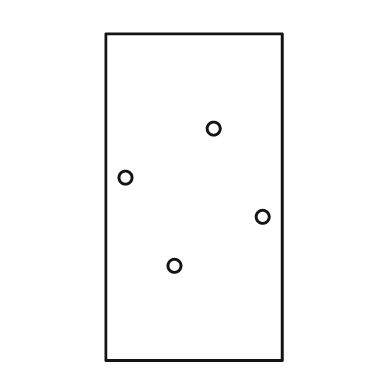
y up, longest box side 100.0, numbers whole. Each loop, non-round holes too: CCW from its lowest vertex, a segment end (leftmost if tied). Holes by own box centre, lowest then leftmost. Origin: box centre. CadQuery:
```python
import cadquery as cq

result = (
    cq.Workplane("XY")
    .moveTo(-27.0, -50.0)
    .lineTo(27.0, -50.0)
    .lineTo(27.0, 50.0)
    .lineTo(-27.0, 50.0)
    .close()
    .moveTo(-6.0, -21.0)
    .circle(2.0)
    .moveTo(21.0, -6.0)
    .circle(2.0)
    .moveTo(-21.0, 6.0)
    .circle(2.0)
    .moveTo(6.0, 21.0)
    .circle(2.0)
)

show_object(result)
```